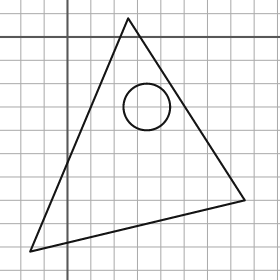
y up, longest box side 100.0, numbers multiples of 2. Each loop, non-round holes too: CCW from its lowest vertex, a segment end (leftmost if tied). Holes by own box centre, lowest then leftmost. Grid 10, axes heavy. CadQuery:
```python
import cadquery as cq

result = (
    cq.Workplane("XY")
    .moveTo(-16.0, -92.0)
    .lineTo(76.0, -70.0)
    .lineTo(26.0, 8.0)
    .close()
    .moveTo(34.0, -30.0)
    .circle(10.0)
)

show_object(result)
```